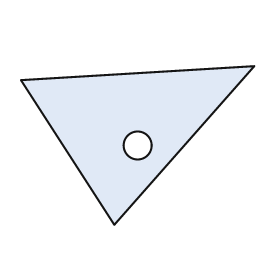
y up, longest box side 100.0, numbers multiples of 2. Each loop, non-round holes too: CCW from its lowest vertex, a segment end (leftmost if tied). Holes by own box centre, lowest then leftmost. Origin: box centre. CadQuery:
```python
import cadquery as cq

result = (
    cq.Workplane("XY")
    .moveTo(-10.0, -34.0)
    .lineTo(50.0, 34.0)
    .lineTo(-50.0, 28.0)
    .close()
    .moveTo(0.0, 0.0)
    .circle(6.0)
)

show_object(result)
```